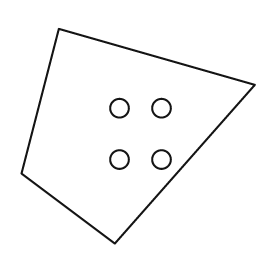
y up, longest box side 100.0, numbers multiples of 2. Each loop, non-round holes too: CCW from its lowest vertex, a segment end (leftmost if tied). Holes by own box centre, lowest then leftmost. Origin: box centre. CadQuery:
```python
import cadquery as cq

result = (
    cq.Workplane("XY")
    .moveTo(-10.0, -46.0)
    .lineTo(50.0, 22.0)
    .lineTo(-34.0, 46.0)
    .lineTo(-50.0, -16.0)
    .close()
    .moveTo(-8.0, -10.0)
    .circle(4.0)
    .moveTo(10.0, -10.0)
    .circle(4.0)
    .moveTo(-8.0, 12.0)
    .circle(4.0)
    .moveTo(10.0, 12.0)
    .circle(4.0)
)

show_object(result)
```